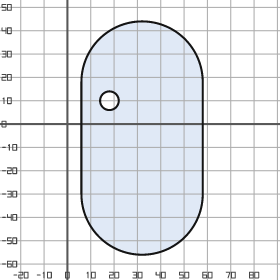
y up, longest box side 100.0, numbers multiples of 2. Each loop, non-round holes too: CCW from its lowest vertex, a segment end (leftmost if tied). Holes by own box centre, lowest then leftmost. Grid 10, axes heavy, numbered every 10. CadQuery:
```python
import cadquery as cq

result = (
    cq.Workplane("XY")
    .moveTo(6.0, -30.0)
    .threePointArc((32.0, -56.0), (58.0, -30.0))
    .lineTo(58.0, 18.0)
    .threePointArc((32.0, 44.0), (6.0, 18.0))
    .close()
    .moveTo(18.0, 10.0)
    .circle(4.0)
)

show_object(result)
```